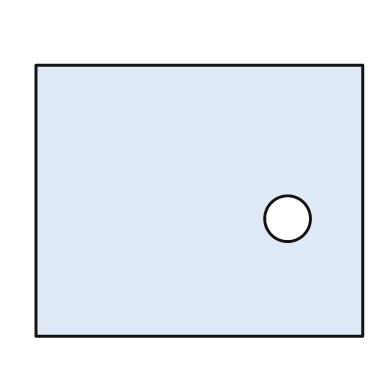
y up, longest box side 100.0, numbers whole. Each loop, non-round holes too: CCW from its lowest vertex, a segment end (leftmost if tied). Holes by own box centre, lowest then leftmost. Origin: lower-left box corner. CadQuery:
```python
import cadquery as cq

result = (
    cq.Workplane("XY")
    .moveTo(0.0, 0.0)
    .lineTo(100.0, 0.0)
    .lineTo(100.0, 83.0)
    .lineTo(0.0, 83.0)
    .close()
    .moveTo(77.0, 36.0)
    .circle(7.0)
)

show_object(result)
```